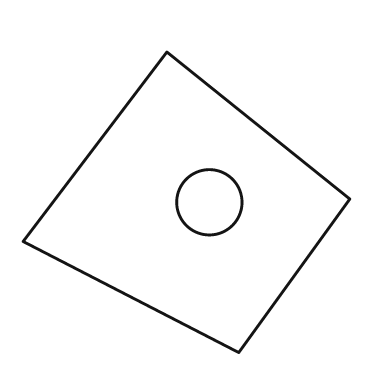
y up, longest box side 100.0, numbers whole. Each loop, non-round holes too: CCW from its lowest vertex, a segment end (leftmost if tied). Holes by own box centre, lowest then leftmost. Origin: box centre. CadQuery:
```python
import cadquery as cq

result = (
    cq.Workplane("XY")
    .moveTo(16.0, -46.0)
    .lineTo(50.0, 1.0)
    .lineTo(-6.0, 46.0)
    .lineTo(-50.0, -12.0)
    .close()
    .moveTo(7.0, 0.0)
    .circle(10.0)
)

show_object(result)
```